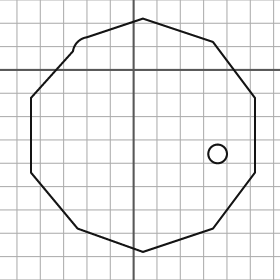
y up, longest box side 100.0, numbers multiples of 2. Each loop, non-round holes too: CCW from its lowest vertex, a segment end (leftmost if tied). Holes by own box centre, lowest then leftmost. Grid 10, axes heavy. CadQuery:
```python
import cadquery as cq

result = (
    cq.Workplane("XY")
    .moveTo(4.0, -78.0)
    .lineTo(34.0, -68.0)
    .lineTo(52.0, -44.0)
    .lineTo(52.0, -12.0)
    .lineTo(34.0, 12.0)
    .lineTo(4.0, 22.0)
    .lineTo(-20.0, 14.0)
    .threePointArc((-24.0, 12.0), (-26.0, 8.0))
    .lineTo(-44.0, -12.0)
    .lineTo(-44.0, -44.0)
    .lineTo(-24.0, -68.0)
    .close()
    .moveTo(36.0, -36.0)
    .circle(4.0)
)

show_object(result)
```